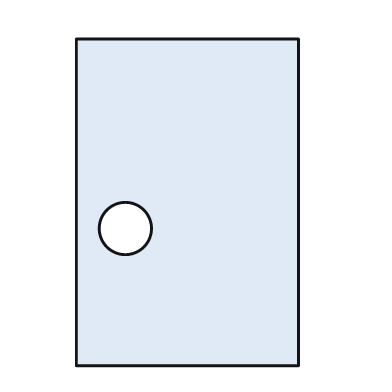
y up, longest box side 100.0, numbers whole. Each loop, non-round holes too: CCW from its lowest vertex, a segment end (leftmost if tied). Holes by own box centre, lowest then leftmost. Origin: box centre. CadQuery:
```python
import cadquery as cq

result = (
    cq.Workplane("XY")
    .moveTo(-34.0, -50.0)
    .lineTo(34.0, -50.0)
    .lineTo(34.0, 50.0)
    .lineTo(-34.0, 50.0)
    .close()
    .moveTo(-19.0, -8.0)
    .circle(8.0)
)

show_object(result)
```